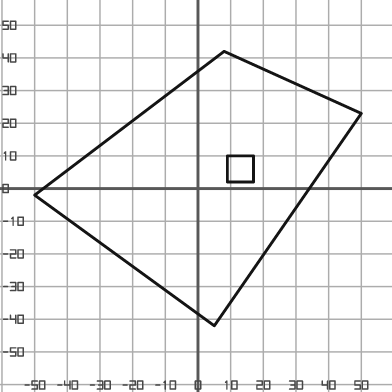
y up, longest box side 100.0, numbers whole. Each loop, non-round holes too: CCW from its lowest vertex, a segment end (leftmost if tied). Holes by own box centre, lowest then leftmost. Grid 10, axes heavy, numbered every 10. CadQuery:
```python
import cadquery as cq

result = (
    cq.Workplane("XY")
    .moveTo(5.0, -42.0)
    .lineTo(50.0, 23.0)
    .lineTo(8.0, 42.0)
    .lineTo(-50.0, -2.0)
    .close()
    .moveTo(9.0, 2.0)
    .lineTo(17.0, 2.0)
    .lineTo(17.0, 10.0)
    .lineTo(9.0, 10.0)
    .close()
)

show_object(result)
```